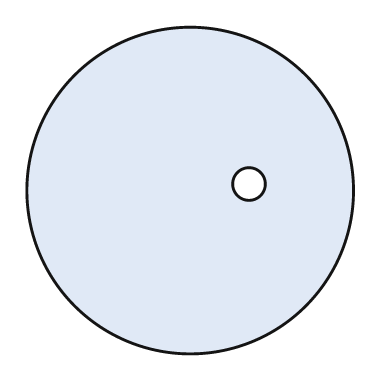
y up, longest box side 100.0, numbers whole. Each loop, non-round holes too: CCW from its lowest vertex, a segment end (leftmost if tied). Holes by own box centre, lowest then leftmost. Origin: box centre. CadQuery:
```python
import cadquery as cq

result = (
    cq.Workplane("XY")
    .moveTo(0.0, 0.0)
    .circle(50.0)
    .moveTo(18.0, 2.0)
    .circle(5.0)
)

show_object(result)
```